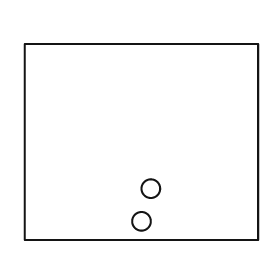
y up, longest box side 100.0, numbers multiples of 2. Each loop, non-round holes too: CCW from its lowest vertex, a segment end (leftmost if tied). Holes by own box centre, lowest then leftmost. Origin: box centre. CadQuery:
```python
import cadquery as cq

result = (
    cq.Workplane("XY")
    .moveTo(-50.0, -42.0)
    .lineTo(50.0, -42.0)
    .lineTo(50.0, 42.0)
    .lineTo(-50.0, 42.0)
    .close()
    .moveTo(0.0, -34.0)
    .circle(4.0)
    .moveTo(4.0, -20.0)
    .circle(4.0)
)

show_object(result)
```